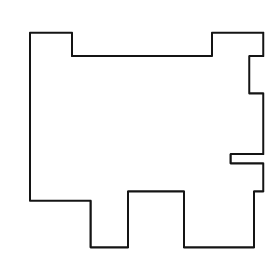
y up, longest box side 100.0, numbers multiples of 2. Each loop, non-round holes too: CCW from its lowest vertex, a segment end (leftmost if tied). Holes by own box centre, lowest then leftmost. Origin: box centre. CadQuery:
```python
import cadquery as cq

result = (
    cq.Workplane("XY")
    .moveTo(-24.0, -46.0)
    .lineTo(-8.0, -46.0)
    .lineTo(-8.0, -22.0)
    .lineTo(16.0, -22.0)
    .lineTo(16.0, -46.0)
    .lineTo(46.0, -46.0)
    .lineTo(46.0, -22.0)
    .lineTo(50.0, -22.0)
    .lineTo(50.0, -10.0)
    .lineTo(36.0, -10.0)
    .lineTo(36.0, -6.0)
    .lineTo(50.0, -6.0)
    .lineTo(50.0, 20.0)
    .lineTo(44.0, 20.0)
    .lineTo(44.0, 36.0)
    .lineTo(50.0, 36.0)
    .lineTo(50.0, 46.0)
    .lineTo(28.0, 46.0)
    .lineTo(28.0, 36.0)
    .lineTo(-32.0, 36.0)
    .lineTo(-32.0, 46.0)
    .lineTo(-50.0, 46.0)
    .lineTo(-50.0, -26.0)
    .lineTo(-24.0, -26.0)
    .close()
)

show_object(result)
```